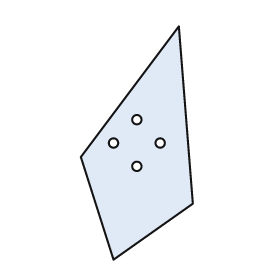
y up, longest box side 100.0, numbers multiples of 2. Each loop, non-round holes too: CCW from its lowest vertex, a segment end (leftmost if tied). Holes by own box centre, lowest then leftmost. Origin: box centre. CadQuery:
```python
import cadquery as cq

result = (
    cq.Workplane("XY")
    .moveTo(-10.0, -50.0)
    .lineTo(24.0, -26.0)
    .lineTo(18.0, 50.0)
    .lineTo(-24.0, -6.0)
    .close()
    .moveTo(0.0, -10.0)
    .circle(2.0)
    .moveTo(-10.0, 0.0)
    .circle(2.0)
    .moveTo(10.0, 0.0)
    .circle(2.0)
    .moveTo(0.0, 10.0)
    .circle(2.0)
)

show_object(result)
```